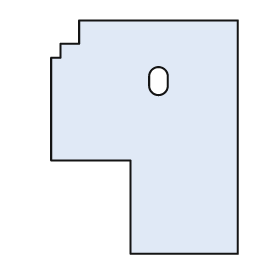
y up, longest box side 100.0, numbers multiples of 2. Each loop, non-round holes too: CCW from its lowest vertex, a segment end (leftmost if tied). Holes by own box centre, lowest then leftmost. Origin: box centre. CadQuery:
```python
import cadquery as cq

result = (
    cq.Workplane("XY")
    .moveTo(-6.0, -50.0)
    .lineTo(40.0, -50.0)
    .lineTo(40.0, 50.0)
    .lineTo(-28.0, 50.0)
    .lineTo(-28.0, 40.0)
    .lineTo(-36.0, 40.0)
    .lineTo(-36.0, 34.0)
    .lineTo(-40.0, 34.0)
    .lineTo(-40.0, -10.0)
    .lineTo(-6.0, -10.0)
    .close()
    .moveTo(2.0, 22.0)
    .threePointArc((6.0, 18.0), (10.0, 22.0))
    .lineTo(10.0, 26.0)
    .threePointArc((6.0, 30.0), (2.0, 26.0))
    .close()
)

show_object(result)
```